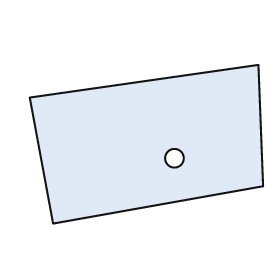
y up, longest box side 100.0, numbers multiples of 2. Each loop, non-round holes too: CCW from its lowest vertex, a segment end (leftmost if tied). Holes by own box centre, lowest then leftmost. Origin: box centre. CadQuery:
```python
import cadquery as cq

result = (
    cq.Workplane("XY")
    .moveTo(-40.0, -34.0)
    .lineTo(50.0, -18.0)
    .lineTo(48.0, 34.0)
    .lineTo(-50.0, 20.0)
    .close()
    .moveTo(12.0, -6.0)
    .circle(4.0)
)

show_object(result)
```